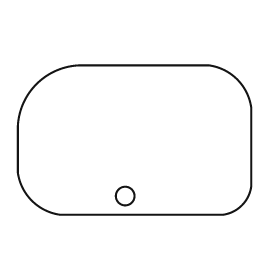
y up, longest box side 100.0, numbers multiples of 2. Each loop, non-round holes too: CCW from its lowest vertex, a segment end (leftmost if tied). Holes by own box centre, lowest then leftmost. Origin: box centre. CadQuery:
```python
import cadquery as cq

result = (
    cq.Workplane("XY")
    .moveTo(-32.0, -32.0)
    .lineTo(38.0, -32.0)
    .threePointArc((46.0, -28.0), (50.0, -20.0))
    .lineTo(50.0, 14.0)
    .threePointArc((44.0, 26.0), (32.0, 32.0))
    .lineTo(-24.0, 32.0)
    .threePointArc((-42.0, 24.0), (-50.0, 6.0))
    .lineTo(-50.0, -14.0)
    .threePointArc((-44.0, -26.0), (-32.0, -32.0))
    .close()
    .moveTo(-4.0, -24.0)
    .circle(4.0)
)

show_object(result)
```